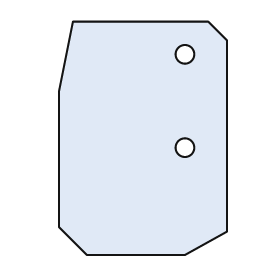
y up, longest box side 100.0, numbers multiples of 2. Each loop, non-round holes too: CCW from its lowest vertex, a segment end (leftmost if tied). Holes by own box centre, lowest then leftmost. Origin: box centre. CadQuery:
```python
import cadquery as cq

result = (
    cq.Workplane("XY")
    .moveTo(-24.0, -50.0)
    .lineTo(18.0, -50.0)
    .lineTo(36.0, -40.0)
    .lineTo(36.0, 42.0)
    .lineTo(28.0, 50.0)
    .lineTo(-30.0, 50.0)
    .lineTo(-36.0, 20.0)
    .lineTo(-36.0, -38.0)
    .close()
    .moveTo(18.0, -4.0)
    .circle(4.0)
    .moveTo(18.0, 36.0)
    .circle(4.0)
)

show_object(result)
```